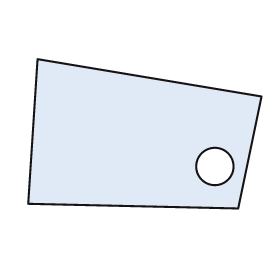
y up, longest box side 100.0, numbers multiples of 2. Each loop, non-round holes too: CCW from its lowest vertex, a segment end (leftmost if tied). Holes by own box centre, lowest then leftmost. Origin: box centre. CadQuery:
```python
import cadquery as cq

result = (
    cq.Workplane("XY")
    .moveTo(40.0, -32.0)
    .lineTo(50.0, 16.0)
    .lineTo(-46.0, 32.0)
    .lineTo(-50.0, -30.0)
    .close()
    .moveTo(30.0, -14.0)
    .circle(8.0)
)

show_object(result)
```